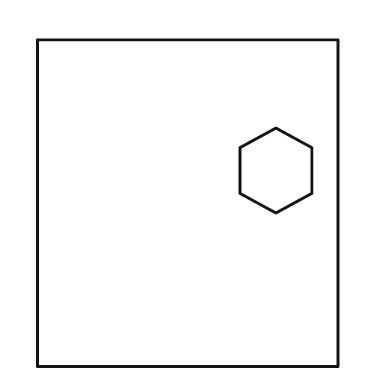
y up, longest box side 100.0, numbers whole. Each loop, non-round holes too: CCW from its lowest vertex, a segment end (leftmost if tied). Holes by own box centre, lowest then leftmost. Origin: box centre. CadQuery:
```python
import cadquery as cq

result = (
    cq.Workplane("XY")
    .moveTo(-46.0, -50.0)
    .lineTo(46.0, -50.0)
    .lineTo(46.0, 50.0)
    .lineTo(-46.0, 50.0)
    .close()
    .moveTo(27.0, -3.0)
    .lineTo(38.0, 3.0)
    .lineTo(38.0, 17.0)
    .lineTo(27.0, 23.0)
    .lineTo(16.0, 17.0)
    .lineTo(16.0, 3.0)
    .close()
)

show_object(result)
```